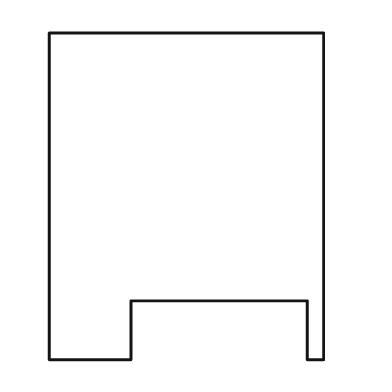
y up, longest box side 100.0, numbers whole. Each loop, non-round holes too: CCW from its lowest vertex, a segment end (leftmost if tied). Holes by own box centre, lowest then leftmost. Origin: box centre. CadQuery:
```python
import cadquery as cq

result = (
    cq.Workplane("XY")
    .moveTo(-42.0, -50.0)
    .lineTo(-17.0, -50.0)
    .lineTo(-17.0, -32.0)
    .lineTo(37.0, -32.0)
    .lineTo(37.0, -50.0)
    .lineTo(42.0, -50.0)
    .lineTo(42.0, 50.0)
    .lineTo(-42.0, 50.0)
    .close()
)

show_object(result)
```